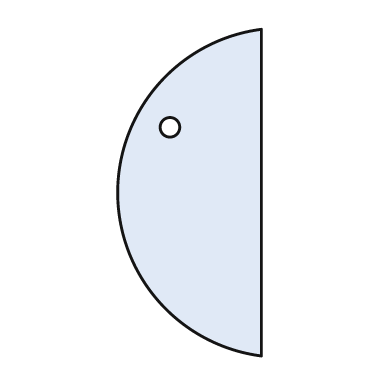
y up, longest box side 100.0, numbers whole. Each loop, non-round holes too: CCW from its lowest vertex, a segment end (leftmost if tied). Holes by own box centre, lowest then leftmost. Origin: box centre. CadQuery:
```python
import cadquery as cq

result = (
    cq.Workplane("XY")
    .moveTo(22.0, -50.0)
    .lineTo(22.0, 50.0)
    .threePointArc((-22.0, 0.0), (22.0, -50.0))
    .close()
    .moveTo(-6.0, 20.0)
    .circle(3.0)
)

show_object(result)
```